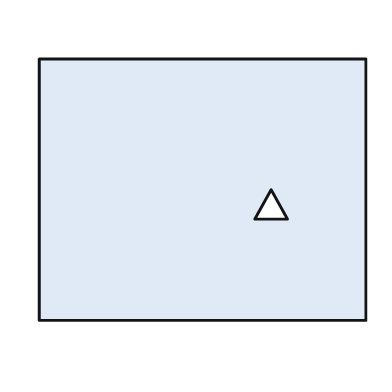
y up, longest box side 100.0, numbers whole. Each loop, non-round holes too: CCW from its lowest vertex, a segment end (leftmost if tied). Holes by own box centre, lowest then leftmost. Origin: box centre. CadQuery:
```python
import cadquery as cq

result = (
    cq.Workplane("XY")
    .moveTo(-50.0, -40.0)
    .lineTo(50.0, -40.0)
    .lineTo(50.0, 40.0)
    .lineTo(-50.0, 40.0)
    .close()
    .moveTo(16.0, -9.0)
    .lineTo(26.0, -9.0)
    .lineTo(21.0, 0.0)
    .close()
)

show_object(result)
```